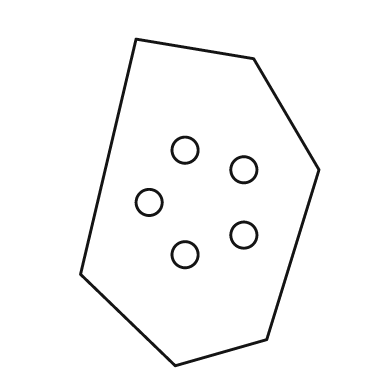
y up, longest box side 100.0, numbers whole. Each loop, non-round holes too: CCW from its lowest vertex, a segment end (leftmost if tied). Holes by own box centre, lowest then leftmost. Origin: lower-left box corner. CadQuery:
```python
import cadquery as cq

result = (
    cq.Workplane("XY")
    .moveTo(29.0, 0.0)
    .lineTo(57.0, 8.0)
    .lineTo(73.0, 60.0)
    .lineTo(53.0, 94.0)
    .lineTo(17.0, 100.0)
    .lineTo(0.0, 28.0)
    .close()
    .moveTo(32.0, 34.0)
    .circle(4.0)
    .moveTo(50.0, 40.0)
    .circle(4.0)
    .moveTo(21.0, 50.0)
    .circle(4.0)
    .moveTo(50.0, 60.0)
    .circle(4.0)
    .moveTo(32.0, 66.0)
    .circle(4.0)
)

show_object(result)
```